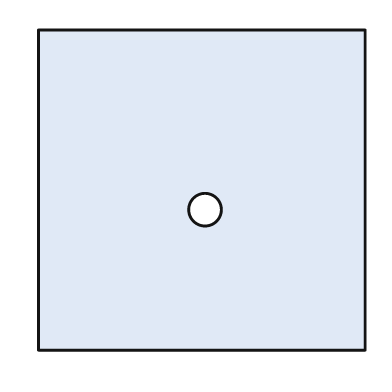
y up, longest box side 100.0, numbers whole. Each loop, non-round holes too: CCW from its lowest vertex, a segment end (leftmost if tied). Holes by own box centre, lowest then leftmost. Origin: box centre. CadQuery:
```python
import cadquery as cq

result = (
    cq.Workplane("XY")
    .moveTo(-50.0, -49.0)
    .lineTo(50.0, -49.0)
    .lineTo(50.0, 49.0)
    .lineTo(-50.0, 49.0)
    .close()
    .moveTo(1.0, -6.0)
    .circle(5.0)
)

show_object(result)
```